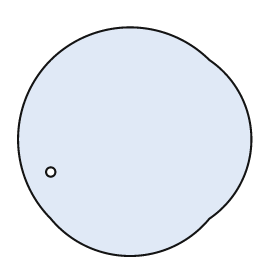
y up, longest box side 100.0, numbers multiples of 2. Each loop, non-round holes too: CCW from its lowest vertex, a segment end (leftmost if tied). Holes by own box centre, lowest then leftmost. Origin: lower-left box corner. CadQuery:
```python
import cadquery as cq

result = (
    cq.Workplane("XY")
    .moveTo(14.0, 16.0)
    .threePointArc((48.0, 0.0), (82.0, 16.0))
    .threePointArc((100.0, 50.0), (82.0, 84.0))
    .threePointArc((48.0, 98.0), (14.0, 84.0))
    .threePointArc((0.0, 50.0), (14.0, 16.0))
    .close()
    .moveTo(14.0, 36.0)
    .circle(2.0)
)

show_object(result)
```